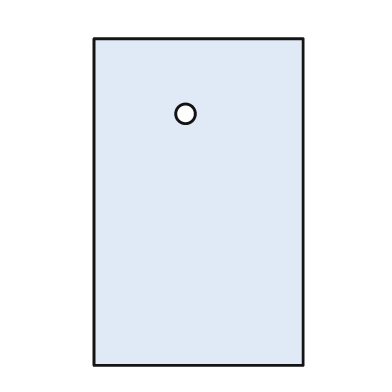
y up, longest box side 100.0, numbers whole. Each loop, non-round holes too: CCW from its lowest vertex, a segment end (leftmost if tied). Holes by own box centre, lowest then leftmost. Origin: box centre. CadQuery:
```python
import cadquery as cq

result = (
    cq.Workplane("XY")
    .moveTo(-32.0, -50.0)
    .lineTo(32.0, -50.0)
    .lineTo(32.0, 50.0)
    .lineTo(-32.0, 50.0)
    .close()
    .moveTo(-4.0, 27.0)
    .circle(3.0)
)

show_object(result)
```